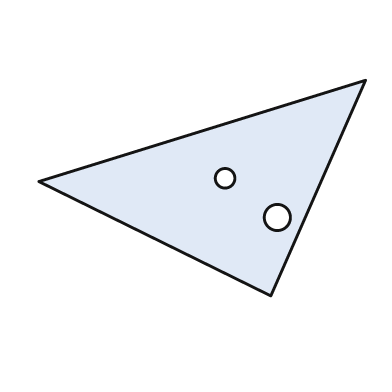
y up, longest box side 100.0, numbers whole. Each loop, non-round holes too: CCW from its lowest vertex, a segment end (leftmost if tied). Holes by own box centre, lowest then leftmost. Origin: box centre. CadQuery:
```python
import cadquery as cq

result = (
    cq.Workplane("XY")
    .moveTo(21.0, -33.0)
    .lineTo(50.0, 33.0)
    .lineTo(-50.0, 2.0)
    .close()
    .moveTo(23.0, -9.0)
    .circle(4.0)
    .moveTo(7.0, 3.0)
    .circle(3.0)
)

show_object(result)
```